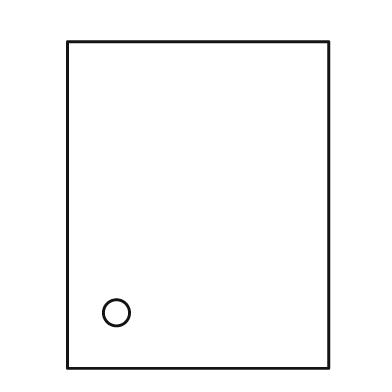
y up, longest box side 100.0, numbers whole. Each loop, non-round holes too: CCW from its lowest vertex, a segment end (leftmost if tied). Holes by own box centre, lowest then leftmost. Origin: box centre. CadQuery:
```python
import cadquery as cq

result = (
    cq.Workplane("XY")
    .moveTo(-40.0, -50.0)
    .lineTo(40.0, -50.0)
    .lineTo(40.0, 50.0)
    .lineTo(-40.0, 50.0)
    .close()
    .moveTo(-25.0, -33.0)
    .circle(4.0)
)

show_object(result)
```